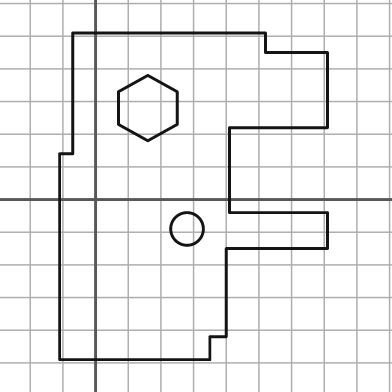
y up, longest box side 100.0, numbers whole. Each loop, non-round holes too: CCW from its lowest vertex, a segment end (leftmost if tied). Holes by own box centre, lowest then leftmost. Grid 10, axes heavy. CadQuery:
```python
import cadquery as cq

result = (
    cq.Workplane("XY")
    .moveTo(-11.0, -49.0)
    .lineTo(35.0, -49.0)
    .lineTo(35.0, -42.0)
    .lineTo(40.0, -42.0)
    .lineTo(40.0, -15.0)
    .lineTo(71.0, -15.0)
    .lineTo(71.0, -4.0)
    .lineTo(41.0, -4.0)
    .lineTo(41.0, 22.0)
    .lineTo(71.0, 22.0)
    .lineTo(71.0, 45.0)
    .lineTo(52.0, 45.0)
    .lineTo(52.0, 51.0)
    .lineTo(-7.0, 51.0)
    .lineTo(-7.0, 14.0)
    .lineTo(-11.0, 14.0)
    .close()
    .moveTo(28.0, -9.0)
    .circle(5.0)
    .moveTo(16.0, 18.0)
    .lineTo(25.0, 23.0)
    .lineTo(25.0, 33.0)
    .lineTo(16.0, 38.0)
    .lineTo(7.0, 33.0)
    .lineTo(7.0, 23.0)
    .close()
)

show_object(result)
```